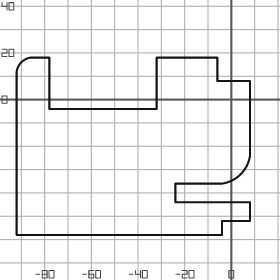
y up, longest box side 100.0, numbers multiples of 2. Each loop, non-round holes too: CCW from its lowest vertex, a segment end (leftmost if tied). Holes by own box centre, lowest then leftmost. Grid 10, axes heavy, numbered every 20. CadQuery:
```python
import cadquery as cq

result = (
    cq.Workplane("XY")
    .moveTo(-92.0, -58.0)
    .lineTo(-4.0, -58.0)
    .lineTo(-4.0, -52.0)
    .lineTo(8.0, -52.0)
    .lineTo(8.0, -44.0)
    .lineTo(-24.0, -44.0)
    .lineTo(-24.0, -36.0)
    .lineTo(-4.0, -36.0)
    .threePointArc((4.0, -32.0), (8.0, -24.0))
    .lineTo(8.0, 8.0)
    .lineTo(-6.0, 8.0)
    .lineTo(-6.0, 18.0)
    .lineTo(-32.0, 18.0)
    .lineTo(-32.0, -4.0)
    .lineTo(-78.0, -4.0)
    .lineTo(-78.0, 18.0)
    .lineTo(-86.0, 18.0)
    .threePointArc((-90.0, 16.0), (-92.0, 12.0))
    .close()
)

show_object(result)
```